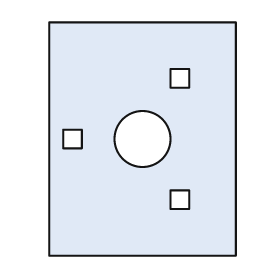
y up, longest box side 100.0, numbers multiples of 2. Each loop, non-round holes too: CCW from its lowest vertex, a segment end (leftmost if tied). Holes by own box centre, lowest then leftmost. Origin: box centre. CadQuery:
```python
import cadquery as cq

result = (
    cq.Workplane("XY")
    .moveTo(-40.0, -50.0)
    .lineTo(40.0, -50.0)
    .lineTo(40.0, 50.0)
    .lineTo(-40.0, 50.0)
    .close()
    .moveTo(12.0, -30.0)
    .lineTo(20.0, -30.0)
    .lineTo(20.0, -22.0)
    .lineTo(12.0, -22.0)
    .close()
    .moveTo(-34.0, -4.0)
    .lineTo(-26.0, -4.0)
    .lineTo(-26.0, 4.0)
    .lineTo(-34.0, 4.0)
    .close()
    .moveTo(0.0, 0.0)
    .circle(12.0)
    .moveTo(12.0, 22.0)
    .lineTo(20.0, 22.0)
    .lineTo(20.0, 30.0)
    .lineTo(12.0, 30.0)
    .close()
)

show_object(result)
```